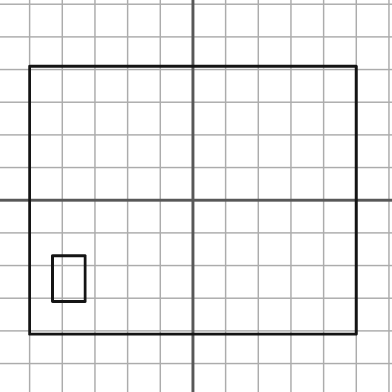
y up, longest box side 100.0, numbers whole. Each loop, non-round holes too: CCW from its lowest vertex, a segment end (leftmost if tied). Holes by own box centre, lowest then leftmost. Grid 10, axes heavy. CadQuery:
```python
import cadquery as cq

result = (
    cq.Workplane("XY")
    .moveTo(-50.0, -41.0)
    .lineTo(50.0, -41.0)
    .lineTo(50.0, 41.0)
    .lineTo(-50.0, 41.0)
    .close()
    .moveTo(-43.0, -31.0)
    .lineTo(-33.0, -31.0)
    .lineTo(-33.0, -17.0)
    .lineTo(-43.0, -17.0)
    .close()
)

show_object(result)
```